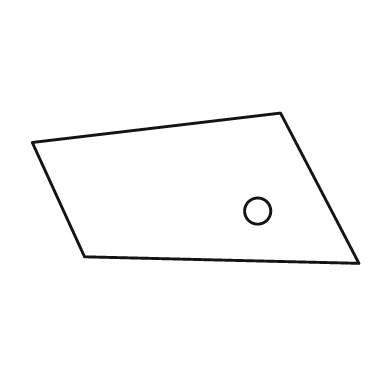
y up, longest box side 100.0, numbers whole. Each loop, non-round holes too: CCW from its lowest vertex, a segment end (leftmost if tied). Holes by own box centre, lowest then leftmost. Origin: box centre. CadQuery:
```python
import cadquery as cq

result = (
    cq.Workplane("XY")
    .moveTo(50.0, -23.0)
    .lineTo(26.0, 23.0)
    .lineTo(-50.0, 14.0)
    .lineTo(-34.0, -21.0)
    .close()
    .moveTo(19.0, -7.0)
    .circle(4.0)
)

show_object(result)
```